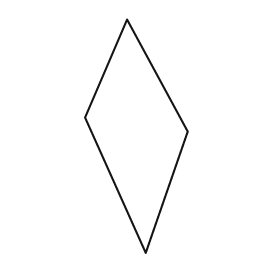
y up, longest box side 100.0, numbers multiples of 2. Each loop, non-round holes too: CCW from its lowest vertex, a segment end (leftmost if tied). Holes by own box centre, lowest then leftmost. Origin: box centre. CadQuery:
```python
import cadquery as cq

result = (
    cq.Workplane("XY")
    .moveTo(4.0, -50.0)
    .lineTo(22.0, 2.0)
    .lineTo(-4.0, 50.0)
    .lineTo(-22.0, 8.0)
    .close()
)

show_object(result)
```